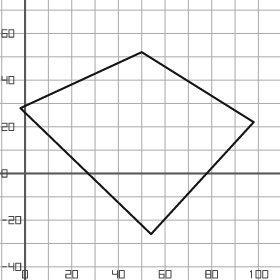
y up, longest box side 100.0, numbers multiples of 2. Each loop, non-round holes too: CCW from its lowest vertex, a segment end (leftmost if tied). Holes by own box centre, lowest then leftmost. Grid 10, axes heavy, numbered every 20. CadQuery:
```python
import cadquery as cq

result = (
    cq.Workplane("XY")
    .moveTo(54.0, -26.0)
    .lineTo(98.0, 22.0)
    .lineTo(50.0, 52.0)
    .lineTo(-2.0, 28.0)
    .close()
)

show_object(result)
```